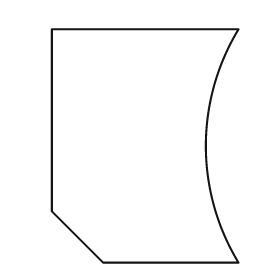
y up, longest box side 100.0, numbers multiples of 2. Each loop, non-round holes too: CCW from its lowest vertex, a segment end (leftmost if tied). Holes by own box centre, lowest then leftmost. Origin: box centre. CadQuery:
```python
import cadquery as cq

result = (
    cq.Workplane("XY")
    .moveTo(-18.0, -50.0)
    .lineTo(40.0, -50.0)
    .threePointArc((26.0, 0.0), (40.0, 50.0))
    .lineTo(-40.0, 50.0)
    .lineTo(-40.0, -28.0)
    .close()
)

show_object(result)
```